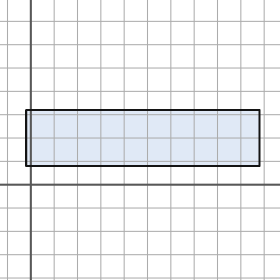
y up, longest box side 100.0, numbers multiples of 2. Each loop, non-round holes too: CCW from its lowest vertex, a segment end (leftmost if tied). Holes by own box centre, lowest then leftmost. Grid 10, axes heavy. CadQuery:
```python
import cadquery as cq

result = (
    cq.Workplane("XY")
    .moveTo(-2.0, 8.0)
    .lineTo(98.0, 8.0)
    .lineTo(98.0, 32.0)
    .lineTo(-2.0, 32.0)
    .close()
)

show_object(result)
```